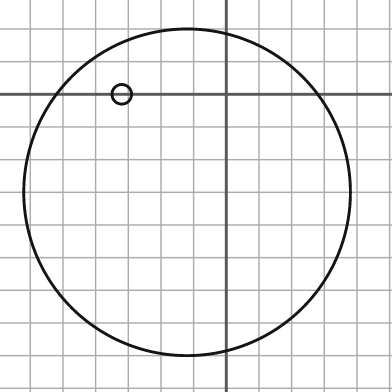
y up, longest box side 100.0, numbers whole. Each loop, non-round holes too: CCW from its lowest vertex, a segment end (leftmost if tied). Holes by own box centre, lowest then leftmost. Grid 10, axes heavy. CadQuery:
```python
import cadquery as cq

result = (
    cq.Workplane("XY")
    .moveTo(-12.0, -30.0)
    .circle(50.0)
    .moveTo(-32.0, 0.0)
    .circle(3.0)
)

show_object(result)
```